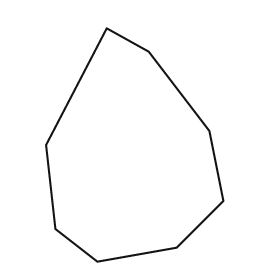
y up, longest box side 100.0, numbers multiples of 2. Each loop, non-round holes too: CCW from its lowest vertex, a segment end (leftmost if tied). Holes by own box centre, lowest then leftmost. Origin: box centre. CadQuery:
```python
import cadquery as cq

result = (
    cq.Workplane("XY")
    .moveTo(-16.0, -50.0)
    .lineTo(18.0, -44.0)
    .lineTo(38.0, -24.0)
    .lineTo(32.0, 6.0)
    .lineTo(6.0, 40.0)
    .lineTo(-12.0, 50.0)
    .lineTo(-38.0, 0.0)
    .lineTo(-34.0, -36.0)
    .close()
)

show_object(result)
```